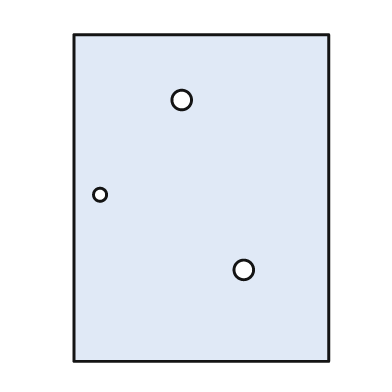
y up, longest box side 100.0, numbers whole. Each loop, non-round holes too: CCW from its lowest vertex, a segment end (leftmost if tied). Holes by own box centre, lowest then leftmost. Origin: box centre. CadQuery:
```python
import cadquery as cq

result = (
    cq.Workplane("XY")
    .moveTo(-39.0, -50.0)
    .lineTo(39.0, -50.0)
    .lineTo(39.0, 50.0)
    .lineTo(-39.0, 50.0)
    .close()
    .moveTo(13.0, -22.0)
    .circle(3.0)
    .moveTo(-31.0, 1.0)
    .circle(2.0)
    .moveTo(-6.0, 30.0)
    .circle(3.0)
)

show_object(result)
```